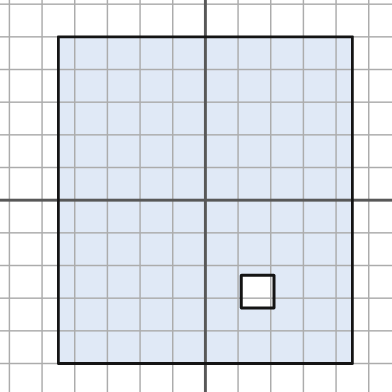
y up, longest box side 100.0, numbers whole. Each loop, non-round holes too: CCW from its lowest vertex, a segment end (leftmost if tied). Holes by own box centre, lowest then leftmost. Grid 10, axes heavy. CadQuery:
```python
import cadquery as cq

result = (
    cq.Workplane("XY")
    .moveTo(-45.0, -50.0)
    .lineTo(45.0, -50.0)
    .lineTo(45.0, 50.0)
    .lineTo(-45.0, 50.0)
    .close()
    .moveTo(11.0, -33.0)
    .lineTo(21.0, -33.0)
    .lineTo(21.0, -23.0)
    .lineTo(11.0, -23.0)
    .close()
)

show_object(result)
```